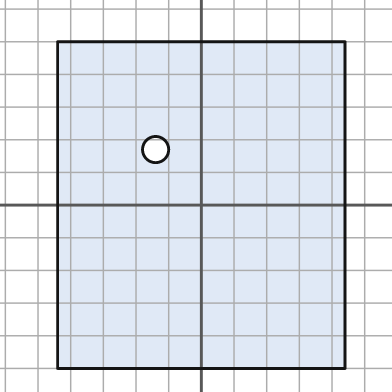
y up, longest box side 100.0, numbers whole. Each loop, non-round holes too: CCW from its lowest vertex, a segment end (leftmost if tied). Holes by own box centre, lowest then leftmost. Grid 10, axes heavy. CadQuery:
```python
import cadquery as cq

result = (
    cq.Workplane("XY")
    .moveTo(-44.0, -50.0)
    .lineTo(44.0, -50.0)
    .lineTo(44.0, 50.0)
    .lineTo(-44.0, 50.0)
    .close()
    .moveTo(-14.0, 17.0)
    .circle(4.0)
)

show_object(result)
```